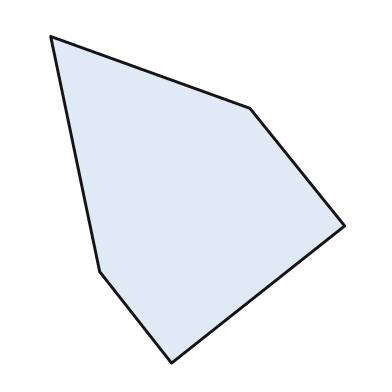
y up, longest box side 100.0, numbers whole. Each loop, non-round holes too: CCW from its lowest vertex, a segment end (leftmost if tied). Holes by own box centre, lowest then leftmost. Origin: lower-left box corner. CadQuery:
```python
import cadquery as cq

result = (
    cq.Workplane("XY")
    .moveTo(37.0, 0.0)
    .lineTo(90.0, 42.0)
    .lineTo(61.0, 78.0)
    .lineTo(0.0, 100.0)
    .lineTo(15.0, 28.0)
    .close()
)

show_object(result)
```